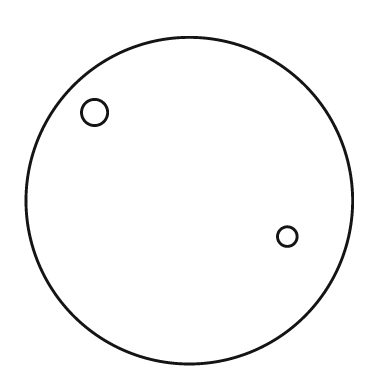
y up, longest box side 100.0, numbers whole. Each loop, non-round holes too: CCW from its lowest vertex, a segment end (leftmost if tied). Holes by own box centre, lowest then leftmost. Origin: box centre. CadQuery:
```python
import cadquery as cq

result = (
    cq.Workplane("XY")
    .moveTo(0.0, 0.0)
    .circle(50.0)
    .moveTo(30.0, -11.0)
    .circle(3.0)
    .moveTo(-29.0, 27.0)
    .circle(4.0)
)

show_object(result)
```